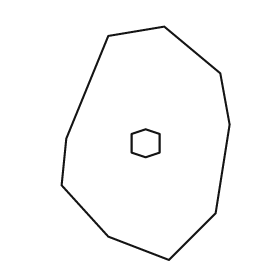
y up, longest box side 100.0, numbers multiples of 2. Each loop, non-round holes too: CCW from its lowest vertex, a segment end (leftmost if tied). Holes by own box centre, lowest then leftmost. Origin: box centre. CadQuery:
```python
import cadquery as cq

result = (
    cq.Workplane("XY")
    .moveTo(10.0, -50.0)
    .lineTo(30.0, -30.0)
    .lineTo(36.0, 8.0)
    .lineTo(32.0, 30.0)
    .lineTo(8.0, 50.0)
    .lineTo(-16.0, 46.0)
    .lineTo(-34.0, 2.0)
    .lineTo(-36.0, -18.0)
    .lineTo(-16.0, -40.0)
    .close()
    .moveTo(0.0, -6.0)
    .lineTo(6.0, -4.0)
    .lineTo(6.0, 4.0)
    .lineTo(0.0, 6.0)
    .lineTo(-6.0, 4.0)
    .lineTo(-6.0, -4.0)
    .close()
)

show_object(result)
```